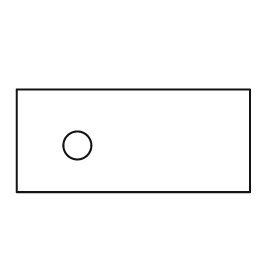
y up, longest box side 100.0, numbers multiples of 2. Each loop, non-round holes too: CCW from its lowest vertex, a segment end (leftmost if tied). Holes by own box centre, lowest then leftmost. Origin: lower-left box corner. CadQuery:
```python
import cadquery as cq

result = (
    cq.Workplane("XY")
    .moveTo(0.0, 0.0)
    .lineTo(100.0, 0.0)
    .lineTo(100.0, 44.0)
    .lineTo(0.0, 44.0)
    .close()
    .moveTo(26.0, 20.0)
    .circle(6.0)
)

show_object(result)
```